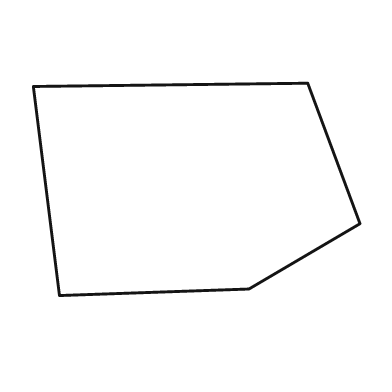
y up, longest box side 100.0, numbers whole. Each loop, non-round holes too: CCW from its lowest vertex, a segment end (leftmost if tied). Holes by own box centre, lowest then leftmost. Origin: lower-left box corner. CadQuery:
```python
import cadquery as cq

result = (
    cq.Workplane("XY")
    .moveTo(8.0, 0.0)
    .lineTo(66.0, 2.0)
    .lineTo(100.0, 22.0)
    .lineTo(84.0, 65.0)
    .lineTo(0.0, 64.0)
    .close()
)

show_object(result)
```